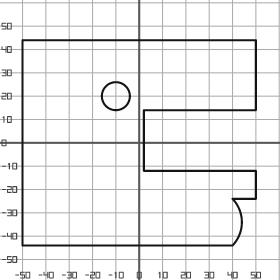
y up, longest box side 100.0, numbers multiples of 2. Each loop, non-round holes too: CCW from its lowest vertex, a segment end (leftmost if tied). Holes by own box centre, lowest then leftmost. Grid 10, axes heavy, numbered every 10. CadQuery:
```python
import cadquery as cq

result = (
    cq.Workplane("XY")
    .moveTo(-50.0, -44.0)
    .lineTo(40.0, -44.0)
    .threePointArc((44.0, -34.0), (40.0, -24.0))
    .lineTo(50.0, -24.0)
    .lineTo(50.0, -12.0)
    .lineTo(2.0, -12.0)
    .lineTo(2.0, 14.0)
    .lineTo(50.0, 14.0)
    .lineTo(50.0, 44.0)
    .lineTo(-50.0, 44.0)
    .close()
    .moveTo(-10.0, 20.0)
    .circle(6.0)
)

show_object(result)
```